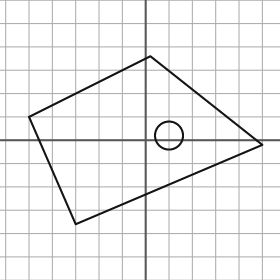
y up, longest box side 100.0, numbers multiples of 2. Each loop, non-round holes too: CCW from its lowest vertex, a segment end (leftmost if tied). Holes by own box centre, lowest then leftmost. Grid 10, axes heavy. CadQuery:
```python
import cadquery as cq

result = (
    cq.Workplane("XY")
    .moveTo(-30.0, -36.0)
    .lineTo(50.0, -2.0)
    .lineTo(2.0, 36.0)
    .lineTo(-50.0, 10.0)
    .close()
    .moveTo(10.0, 2.0)
    .circle(6.0)
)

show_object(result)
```